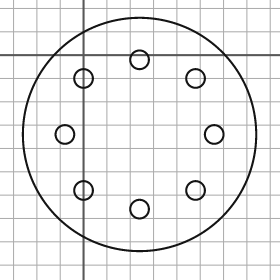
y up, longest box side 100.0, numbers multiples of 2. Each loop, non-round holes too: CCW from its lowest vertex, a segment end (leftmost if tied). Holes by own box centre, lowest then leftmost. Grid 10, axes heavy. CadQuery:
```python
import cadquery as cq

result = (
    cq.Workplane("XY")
    .moveTo(24.0, -34.0)
    .circle(50.0)
    .moveTo(24.0, -66.0)
    .circle(4.0)
    .moveTo(0.0, -58.0)
    .circle(4.0)
    .moveTo(48.0, -58.0)
    .circle(4.0)
    .moveTo(-8.0, -34.0)
    .circle(4.0)
    .moveTo(56.0, -34.0)
    .circle(4.0)
    .moveTo(0.0, -10.0)
    .circle(4.0)
    .moveTo(48.0, -10.0)
    .circle(4.0)
    .moveTo(24.0, -2.0)
    .circle(4.0)
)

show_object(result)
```